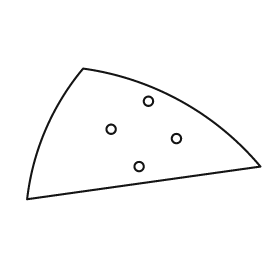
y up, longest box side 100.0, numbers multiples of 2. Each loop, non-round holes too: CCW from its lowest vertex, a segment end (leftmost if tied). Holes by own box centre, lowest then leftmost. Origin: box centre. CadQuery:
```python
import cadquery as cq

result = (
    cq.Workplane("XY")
    .moveTo(-50.0, -28.0)
    .lineTo(50.0, -14.0)
    .threePointArc((16.0, 14.0), (-26.0, 28.0))
    .threePointArc((-42.0, 2.0), (-50.0, -28.0))
    .close()
    .moveTo(-2.0, -14.0)
    .circle(2.0)
    .moveTo(14.0, -2.0)
    .circle(2.0)
    .moveTo(-14.0, 2.0)
    .circle(2.0)
    .moveTo(2.0, 14.0)
    .circle(2.0)
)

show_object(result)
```